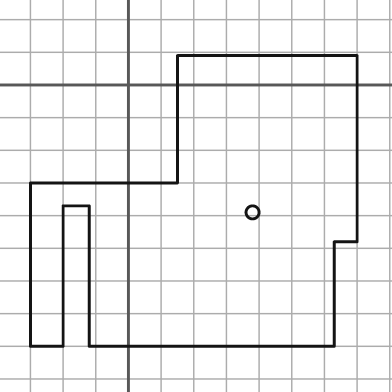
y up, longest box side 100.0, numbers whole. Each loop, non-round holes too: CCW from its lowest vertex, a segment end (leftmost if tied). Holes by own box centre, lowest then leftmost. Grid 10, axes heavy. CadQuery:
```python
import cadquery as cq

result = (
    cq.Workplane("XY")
    .moveTo(-30.0, -80.0)
    .lineTo(-20.0, -80.0)
    .lineTo(-20.0, -37.0)
    .lineTo(-12.0, -37.0)
    .lineTo(-12.0, -80.0)
    .lineTo(63.0, -80.0)
    .lineTo(63.0, -48.0)
    .lineTo(70.0, -48.0)
    .lineTo(70.0, 9.0)
    .lineTo(15.0, 9.0)
    .lineTo(15.0, -30.0)
    .lineTo(-30.0, -30.0)
    .close()
    .moveTo(38.0, -39.0)
    .circle(2.0)
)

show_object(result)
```